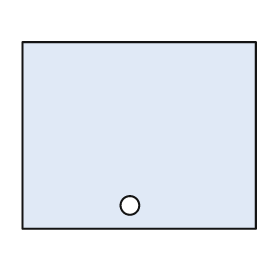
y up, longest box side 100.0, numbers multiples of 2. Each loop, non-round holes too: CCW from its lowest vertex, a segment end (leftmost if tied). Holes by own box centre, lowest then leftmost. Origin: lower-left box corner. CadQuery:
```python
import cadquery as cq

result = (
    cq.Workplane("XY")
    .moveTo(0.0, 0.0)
    .lineTo(100.0, 0.0)
    .lineTo(100.0, 80.0)
    .lineTo(0.0, 80.0)
    .close()
    .moveTo(46.0, 10.0)
    .circle(4.0)
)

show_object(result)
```